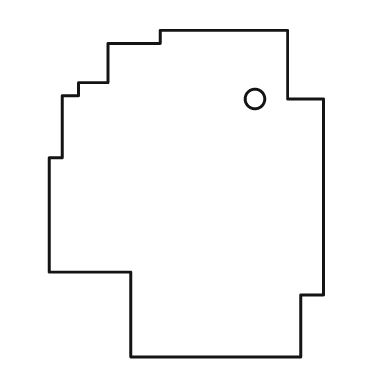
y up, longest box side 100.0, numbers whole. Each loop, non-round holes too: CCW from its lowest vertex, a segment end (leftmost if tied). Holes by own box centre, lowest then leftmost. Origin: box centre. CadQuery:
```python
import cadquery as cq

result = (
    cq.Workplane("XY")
    .moveTo(-17.0, -50.0)
    .lineTo(35.0, -50.0)
    .lineTo(35.0, -31.0)
    .lineTo(42.0, -31.0)
    .lineTo(42.0, 29.0)
    .lineTo(31.0, 29.0)
    .lineTo(31.0, 50.0)
    .lineTo(-8.0, 50.0)
    .lineTo(-8.0, 46.0)
    .lineTo(-24.0, 46.0)
    .lineTo(-24.0, 34.0)
    .lineTo(-33.0, 34.0)
    .lineTo(-33.0, 30.0)
    .lineTo(-38.0, 30.0)
    .lineTo(-38.0, 11.0)
    .lineTo(-42.0, 11.0)
    .lineTo(-42.0, -24.0)
    .lineTo(-17.0, -24.0)
    .close()
    .moveTo(21.0, 29.0)
    .circle(3.0)
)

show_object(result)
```